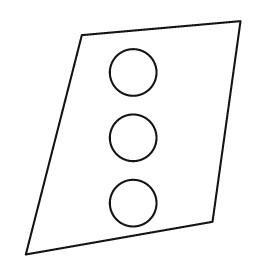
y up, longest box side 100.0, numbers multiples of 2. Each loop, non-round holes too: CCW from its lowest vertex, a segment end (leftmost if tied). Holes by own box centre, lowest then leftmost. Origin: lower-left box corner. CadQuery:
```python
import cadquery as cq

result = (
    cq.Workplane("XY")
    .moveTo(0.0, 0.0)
    .lineTo(80.0, 14.0)
    .lineTo(92.0, 100.0)
    .lineTo(24.0, 94.0)
    .close()
    .moveTo(46.0, 22.0)
    .circle(10.0)
    .moveTo(46.0, 50.0)
    .circle(10.0)
    .moveTo(46.0, 78.0)
    .circle(10.0)
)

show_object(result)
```